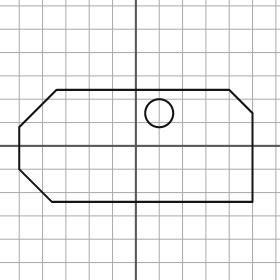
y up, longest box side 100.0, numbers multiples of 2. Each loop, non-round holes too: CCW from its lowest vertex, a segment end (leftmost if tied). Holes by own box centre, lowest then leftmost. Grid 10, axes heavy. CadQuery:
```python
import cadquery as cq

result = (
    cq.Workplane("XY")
    .moveTo(-36.0, -24.0)
    .lineTo(50.0, -24.0)
    .lineTo(50.0, 14.0)
    .lineTo(40.0, 24.0)
    .lineTo(-34.0, 24.0)
    .lineTo(-50.0, 8.0)
    .lineTo(-50.0, -10.0)
    .close()
    .moveTo(10.0, 14.0)
    .circle(6.0)
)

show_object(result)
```